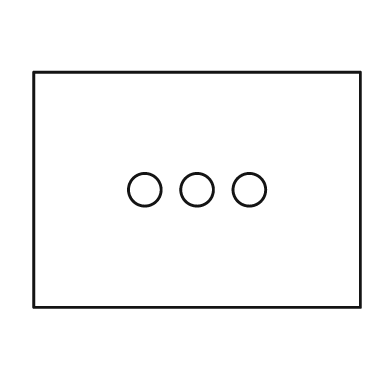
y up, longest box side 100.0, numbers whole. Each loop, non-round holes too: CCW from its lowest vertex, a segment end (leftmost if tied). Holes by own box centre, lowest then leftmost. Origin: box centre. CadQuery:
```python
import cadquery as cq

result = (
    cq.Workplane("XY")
    .moveTo(-50.0, -36.0)
    .lineTo(50.0, -36.0)
    .lineTo(50.0, 36.0)
    .lineTo(-50.0, 36.0)
    .close()
    .moveTo(-16.0, 0.0)
    .circle(5.0)
    .moveTo(0.0, 0.0)
    .circle(5.0)
    .moveTo(16.0, 0.0)
    .circle(5.0)
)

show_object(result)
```